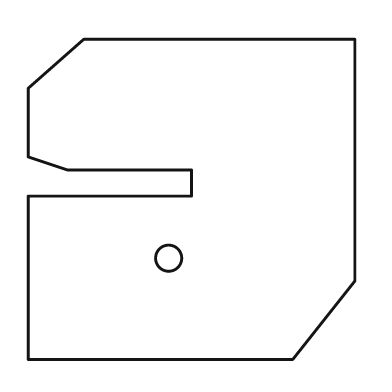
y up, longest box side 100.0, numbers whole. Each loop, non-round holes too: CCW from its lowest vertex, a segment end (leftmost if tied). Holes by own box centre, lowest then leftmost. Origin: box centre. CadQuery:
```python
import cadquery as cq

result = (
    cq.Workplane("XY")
    .moveTo(-50.0, -49.0)
    .lineTo(31.0, -49.0)
    .lineTo(50.0, -25.0)
    .lineTo(50.0, 49.0)
    .lineTo(-33.0, 49.0)
    .lineTo(-50.0, 34.0)
    .lineTo(-50.0, 13.0)
    .lineTo(-38.0, 9.0)
    .lineTo(0.0, 9.0)
    .lineTo(0.0, 1.0)
    .lineTo(-50.0, 1.0)
    .close()
    .moveTo(-7.0, -18.0)
    .circle(4.0)
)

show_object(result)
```